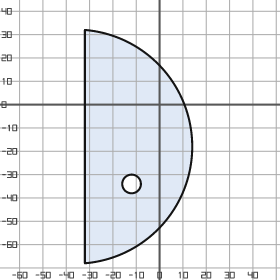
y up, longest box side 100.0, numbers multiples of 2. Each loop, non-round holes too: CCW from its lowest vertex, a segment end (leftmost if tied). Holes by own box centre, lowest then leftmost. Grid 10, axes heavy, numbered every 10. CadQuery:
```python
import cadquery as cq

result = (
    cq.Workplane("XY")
    .moveTo(-32.0, -68.0)
    .threePointArc((14.0, -18.0), (-32.0, 32.0))
    .close()
    .moveTo(-12.0, -34.0)
    .circle(4.0)
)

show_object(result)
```